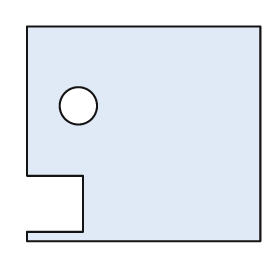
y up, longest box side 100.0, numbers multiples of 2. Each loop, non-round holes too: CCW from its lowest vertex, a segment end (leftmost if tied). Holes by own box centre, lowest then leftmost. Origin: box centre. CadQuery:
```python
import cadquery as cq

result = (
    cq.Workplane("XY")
    .moveTo(-50.0, -46.0)
    .lineTo(50.0, -46.0)
    .lineTo(50.0, 46.0)
    .lineTo(-50.0, 46.0)
    .lineTo(-50.0, -18.0)
    .lineTo(-26.0, -18.0)
    .lineTo(-26.0, -42.0)
    .lineTo(-50.0, -42.0)
    .close()
    .moveTo(-28.0, 12.0)
    .circle(8.0)
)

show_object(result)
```